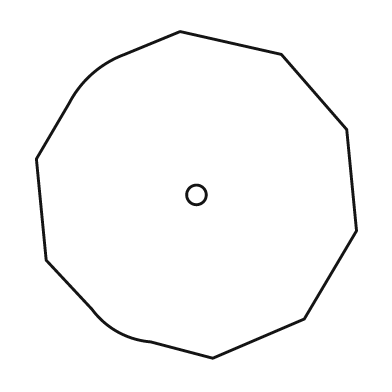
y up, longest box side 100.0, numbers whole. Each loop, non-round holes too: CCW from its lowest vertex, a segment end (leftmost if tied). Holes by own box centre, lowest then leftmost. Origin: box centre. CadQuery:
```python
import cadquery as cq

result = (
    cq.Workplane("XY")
    .moveTo(5.0, -50.0)
    .lineTo(33.0, -38.0)
    .lineTo(49.0, -11.0)
    .lineTo(46.0, 20.0)
    .lineTo(26.0, 43.0)
    .lineTo(-5.0, 50.0)
    .lineTo(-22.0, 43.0)
    .threePointArc((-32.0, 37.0), (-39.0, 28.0))
    .lineTo(-49.0, 11.0)
    .lineTo(-46.0, -20.0)
    .lineTo(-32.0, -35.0)
    .threePointArc((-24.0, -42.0), (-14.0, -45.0))
    .close()
    .moveTo(0.0, 0.0)
    .circle(3.0)
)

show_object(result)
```